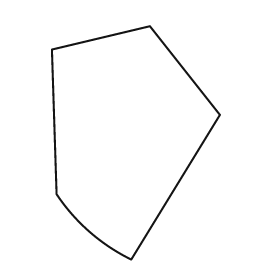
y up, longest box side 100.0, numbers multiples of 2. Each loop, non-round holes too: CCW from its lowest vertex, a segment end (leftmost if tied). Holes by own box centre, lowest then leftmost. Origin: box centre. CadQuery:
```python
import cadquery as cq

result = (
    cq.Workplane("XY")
    .moveTo(-2.0, -50.0)
    .lineTo(36.0, 12.0)
    .lineTo(6.0, 50.0)
    .lineTo(-36.0, 40.0)
    .lineTo(-34.0, -22.0)
    .threePointArc((-20.0, -38.0), (-2.0, -50.0))
    .close()
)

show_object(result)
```